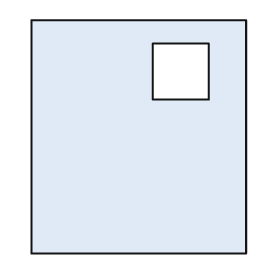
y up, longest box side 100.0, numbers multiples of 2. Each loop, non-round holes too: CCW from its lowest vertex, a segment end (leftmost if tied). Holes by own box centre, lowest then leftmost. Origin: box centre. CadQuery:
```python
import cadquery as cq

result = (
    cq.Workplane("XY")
    .moveTo(-46.0, -50.0)
    .lineTo(46.0, -50.0)
    .lineTo(46.0, 50.0)
    .lineTo(-46.0, 50.0)
    .close()
    .moveTo(6.0, 16.0)
    .lineTo(30.0, 16.0)
    .lineTo(30.0, 40.0)
    .lineTo(6.0, 40.0)
    .close()
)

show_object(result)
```